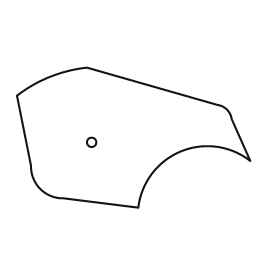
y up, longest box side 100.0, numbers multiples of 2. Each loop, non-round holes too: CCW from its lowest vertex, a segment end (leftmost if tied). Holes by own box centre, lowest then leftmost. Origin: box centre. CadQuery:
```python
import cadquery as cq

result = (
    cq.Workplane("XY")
    .moveTo(2.0, -30.0)
    .threePointArc((20.0, -6.0), (50.0, -10.0))
    .lineTo(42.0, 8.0)
    .threePointArc((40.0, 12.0), (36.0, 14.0))
    .lineTo(-20.0, 30.0)
    .threePointArc((-36.0, 26.0), (-50.0, 18.0))
    .lineTo(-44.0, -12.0)
    .threePointArc((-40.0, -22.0), (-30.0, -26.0))
    .close()
    .moveTo(-18.0, -2.0)
    .circle(2.0)
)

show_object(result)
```